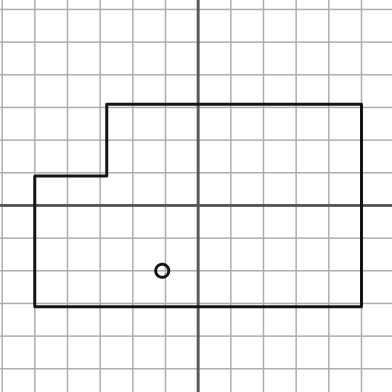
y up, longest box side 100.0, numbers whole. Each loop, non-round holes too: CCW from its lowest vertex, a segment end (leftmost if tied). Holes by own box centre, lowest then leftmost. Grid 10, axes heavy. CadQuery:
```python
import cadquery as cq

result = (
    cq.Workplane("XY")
    .moveTo(-50.0, -31.0)
    .lineTo(50.0, -31.0)
    .lineTo(50.0, 31.0)
    .lineTo(-28.0, 31.0)
    .lineTo(-28.0, 9.0)
    .lineTo(-50.0, 9.0)
    .close()
    .moveTo(-11.0, -20.0)
    .circle(2.0)
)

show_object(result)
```